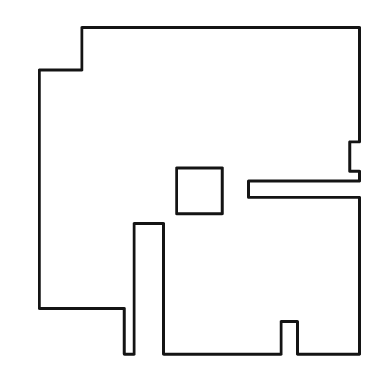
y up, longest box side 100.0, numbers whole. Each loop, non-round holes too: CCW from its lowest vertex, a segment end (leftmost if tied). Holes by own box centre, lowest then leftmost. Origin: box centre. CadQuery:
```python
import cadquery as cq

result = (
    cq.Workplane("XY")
    .moveTo(-23.0, -50.0)
    .lineTo(-20.0, -50.0)
    .lineTo(-20.0, -10.0)
    .lineTo(-11.0, -10.0)
    .lineTo(-11.0, -50.0)
    .lineTo(25.0, -50.0)
    .lineTo(25.0, -40.0)
    .lineTo(30.0, -40.0)
    .lineTo(30.0, -50.0)
    .lineTo(49.0, -50.0)
    .lineTo(49.0, -2.0)
    .lineTo(15.0, -2.0)
    .lineTo(15.0, 3.0)
    .lineTo(49.0, 3.0)
    .lineTo(49.0, 6.0)
    .lineTo(46.0, 6.0)
    .lineTo(46.0, 15.0)
    .lineTo(49.0, 15.0)
    .lineTo(49.0, 50.0)
    .lineTo(-36.0, 50.0)
    .lineTo(-36.0, 37.0)
    .lineTo(-49.0, 37.0)
    .lineTo(-49.0, -36.0)
    .lineTo(-23.0, -36.0)
    .close()
    .moveTo(-7.0, -7.0)
    .lineTo(7.0, -7.0)
    .lineTo(7.0, 7.0)
    .lineTo(-7.0, 7.0)
    .close()
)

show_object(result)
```